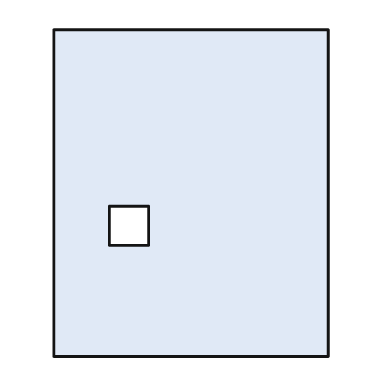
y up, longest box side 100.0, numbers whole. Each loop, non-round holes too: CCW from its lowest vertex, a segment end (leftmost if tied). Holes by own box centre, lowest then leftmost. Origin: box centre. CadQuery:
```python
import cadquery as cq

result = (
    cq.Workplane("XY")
    .moveTo(-42.0, -50.0)
    .lineTo(42.0, -50.0)
    .lineTo(42.0, 50.0)
    .lineTo(-42.0, 50.0)
    .close()
    .moveTo(-25.0, -16.0)
    .lineTo(-13.0, -16.0)
    .lineTo(-13.0, -4.0)
    .lineTo(-25.0, -4.0)
    .close()
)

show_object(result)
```